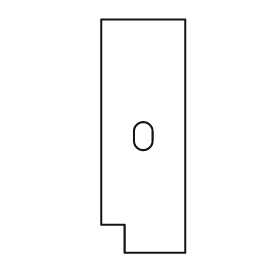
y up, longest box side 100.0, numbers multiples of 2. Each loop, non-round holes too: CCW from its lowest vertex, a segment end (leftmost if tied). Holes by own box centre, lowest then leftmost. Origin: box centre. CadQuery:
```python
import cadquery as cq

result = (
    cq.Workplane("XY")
    .moveTo(-8.0, -50.0)
    .lineTo(18.0, -50.0)
    .lineTo(18.0, 50.0)
    .lineTo(-18.0, 50.0)
    .lineTo(-18.0, -38.0)
    .lineTo(-8.0, -38.0)
    .close()
    .moveTo(-4.0, -2.0)
    .threePointArc((0.0, -6.0), (4.0, -2.0))
    .lineTo(4.0, 2.0)
    .threePointArc((0.0, 6.0), (-4.0, 2.0))
    .close()
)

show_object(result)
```